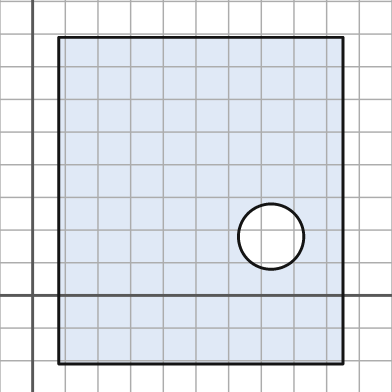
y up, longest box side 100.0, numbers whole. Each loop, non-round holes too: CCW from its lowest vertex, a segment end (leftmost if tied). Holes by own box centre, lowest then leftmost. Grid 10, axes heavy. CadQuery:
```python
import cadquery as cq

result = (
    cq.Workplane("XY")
    .moveTo(8.0, -21.0)
    .lineTo(95.0, -21.0)
    .lineTo(95.0, 79.0)
    .lineTo(8.0, 79.0)
    .close()
    .moveTo(73.0, 18.0)
    .circle(10.0)
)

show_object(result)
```